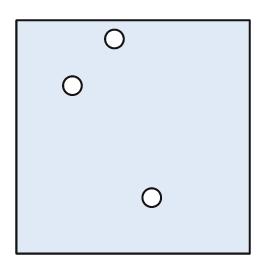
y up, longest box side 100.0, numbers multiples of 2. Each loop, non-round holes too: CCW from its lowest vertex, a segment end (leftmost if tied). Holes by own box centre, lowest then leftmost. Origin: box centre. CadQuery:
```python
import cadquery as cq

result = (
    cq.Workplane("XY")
    .moveTo(-50.0, -50.0)
    .lineTo(50.0, -50.0)
    .lineTo(50.0, 50.0)
    .lineTo(-50.0, 50.0)
    .close()
    .moveTo(8.0, -26.0)
    .circle(4.0)
    .moveTo(-26.0, 22.0)
    .circle(4.0)
    .moveTo(-8.0, 42.0)
    .circle(4.0)
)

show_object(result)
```